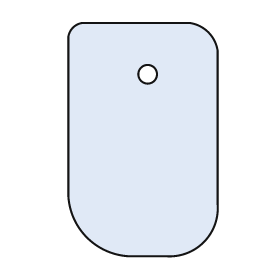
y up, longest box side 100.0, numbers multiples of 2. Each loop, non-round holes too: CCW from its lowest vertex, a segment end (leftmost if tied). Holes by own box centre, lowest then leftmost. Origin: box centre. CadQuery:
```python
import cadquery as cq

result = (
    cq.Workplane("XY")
    .moveTo(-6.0, -50.0)
    .lineTo(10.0, -50.0)
    .threePointArc((26.0, -44.0), (32.0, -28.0))
    .lineTo(32.0, 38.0)
    .threePointArc((28.0, 46.0), (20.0, 50.0))
    .lineTo(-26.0, 50.0)
    .threePointArc((-30.0, 48.0), (-32.0, 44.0))
    .lineTo(-32.0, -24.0)
    .threePointArc((-24.0, -42.0), (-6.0, -50.0))
    .close()
    .moveTo(2.0, 28.0)
    .circle(4.0)
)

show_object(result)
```